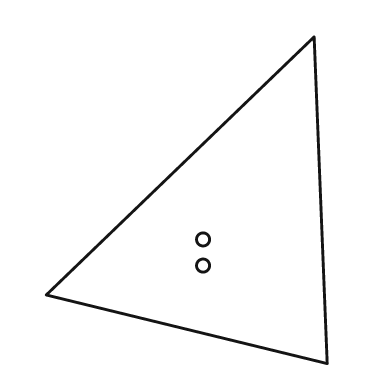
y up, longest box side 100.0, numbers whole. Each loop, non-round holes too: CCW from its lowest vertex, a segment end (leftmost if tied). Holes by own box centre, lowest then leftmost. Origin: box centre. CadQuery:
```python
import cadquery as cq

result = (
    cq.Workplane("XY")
    .moveTo(43.0, -50.0)
    .lineTo(39.0, 50.0)
    .lineTo(-43.0, -29.0)
    .close()
    .moveTo(5.0, -20.0)
    .circle(2.0)
    .moveTo(5.0, -12.0)
    .circle(2.0)
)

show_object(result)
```